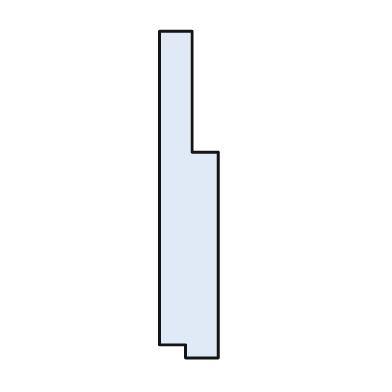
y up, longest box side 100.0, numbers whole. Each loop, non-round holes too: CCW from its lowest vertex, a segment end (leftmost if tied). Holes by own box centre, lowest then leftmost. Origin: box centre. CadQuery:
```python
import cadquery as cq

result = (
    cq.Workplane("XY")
    .moveTo(-1.0, -50.0)
    .lineTo(9.0, -50.0)
    .lineTo(9.0, 13.0)
    .lineTo(1.0, 13.0)
    .lineTo(1.0, 50.0)
    .lineTo(-9.0, 50.0)
    .lineTo(-9.0, -46.0)
    .lineTo(-1.0, -46.0)
    .close()
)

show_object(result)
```